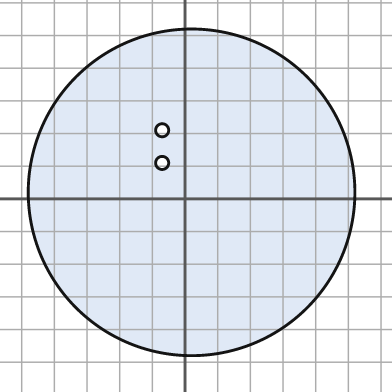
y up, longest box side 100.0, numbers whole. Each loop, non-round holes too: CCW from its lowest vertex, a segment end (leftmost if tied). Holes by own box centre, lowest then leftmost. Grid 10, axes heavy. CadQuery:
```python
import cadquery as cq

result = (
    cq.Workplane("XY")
    .moveTo(2.0, 2.0)
    .circle(50.0)
    .moveTo(-7.0, 11.0)
    .circle(2.0)
    .moveTo(-7.0, 21.0)
    .circle(2.0)
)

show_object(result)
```